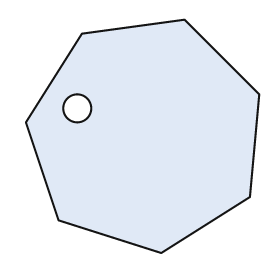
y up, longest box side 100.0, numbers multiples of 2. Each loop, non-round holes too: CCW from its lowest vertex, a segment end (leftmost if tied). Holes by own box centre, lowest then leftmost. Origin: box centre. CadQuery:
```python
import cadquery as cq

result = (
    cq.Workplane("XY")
    .moveTo(8.0, -50.0)
    .lineTo(46.0, -26.0)
    .lineTo(50.0, 18.0)
    .lineTo(18.0, 50.0)
    .lineTo(-26.0, 44.0)
    .lineTo(-50.0, 6.0)
    .lineTo(-36.0, -36.0)
    .close()
    .moveTo(-28.0, 12.0)
    .circle(6.0)
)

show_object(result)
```